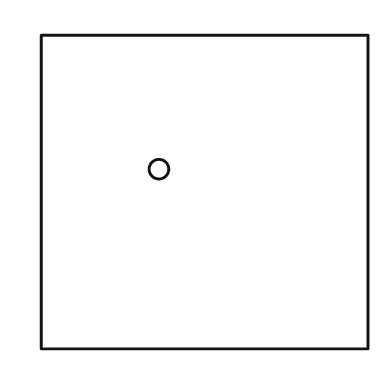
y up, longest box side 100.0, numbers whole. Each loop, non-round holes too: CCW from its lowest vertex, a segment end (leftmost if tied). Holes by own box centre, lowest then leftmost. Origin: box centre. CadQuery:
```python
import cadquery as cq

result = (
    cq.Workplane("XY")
    .moveTo(-50.0, -48.0)
    .lineTo(50.0, -48.0)
    .lineTo(50.0, 48.0)
    .lineTo(-50.0, 48.0)
    .close()
    .moveTo(-14.0, 7.0)
    .circle(3.0)
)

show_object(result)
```